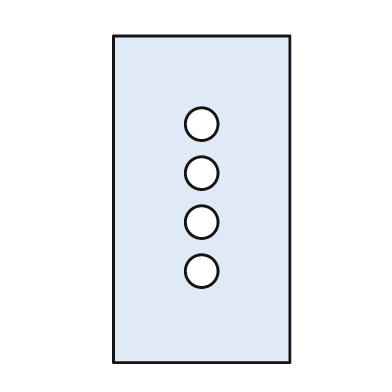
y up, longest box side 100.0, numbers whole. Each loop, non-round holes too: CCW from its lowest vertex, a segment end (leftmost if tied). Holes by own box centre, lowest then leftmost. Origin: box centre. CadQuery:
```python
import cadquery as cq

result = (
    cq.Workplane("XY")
    .moveTo(-27.0, -50.0)
    .lineTo(27.0, -50.0)
    .lineTo(27.0, 50.0)
    .lineTo(-27.0, 50.0)
    .close()
    .moveTo(0.0, -22.0)
    .circle(5.0)
    .moveTo(0.0, -7.0)
    .circle(5.0)
    .moveTo(0.0, 8.0)
    .circle(5.0)
    .moveTo(0.0, 23.0)
    .circle(5.0)
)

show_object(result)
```